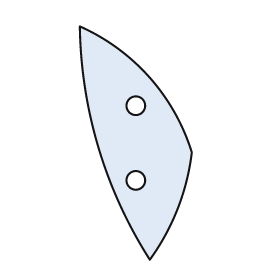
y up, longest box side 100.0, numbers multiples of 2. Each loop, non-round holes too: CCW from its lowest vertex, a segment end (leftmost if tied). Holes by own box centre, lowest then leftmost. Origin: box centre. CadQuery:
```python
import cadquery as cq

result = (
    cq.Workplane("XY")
    .moveTo(6.0, -50.0)
    .threePointArc((18.0, -28.0), (24.0, -4.0))
    .threePointArc((6.0, 28.0), (-24.0, 50.0))
    .threePointArc((-16.0, -2.0), (6.0, -50.0))
    .close()
    .moveTo(0.0, -16.0)
    .circle(4.0)
    .moveTo(0.0, 16.0)
    .circle(4.0)
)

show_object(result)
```